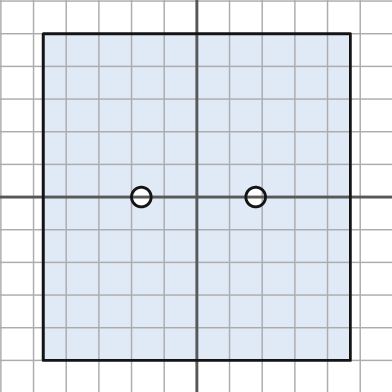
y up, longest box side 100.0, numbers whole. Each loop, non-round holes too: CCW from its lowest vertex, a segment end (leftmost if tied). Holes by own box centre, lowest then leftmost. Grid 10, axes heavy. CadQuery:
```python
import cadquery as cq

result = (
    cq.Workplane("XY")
    .moveTo(-47.0, -50.0)
    .lineTo(47.0, -50.0)
    .lineTo(47.0, 50.0)
    .lineTo(-47.0, 50.0)
    .close()
    .moveTo(-17.0, 0.0)
    .circle(3.0)
    .moveTo(18.0, 0.0)
    .circle(3.0)
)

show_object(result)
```